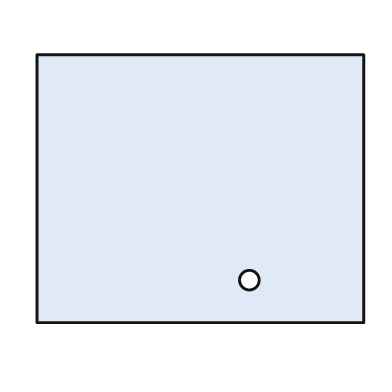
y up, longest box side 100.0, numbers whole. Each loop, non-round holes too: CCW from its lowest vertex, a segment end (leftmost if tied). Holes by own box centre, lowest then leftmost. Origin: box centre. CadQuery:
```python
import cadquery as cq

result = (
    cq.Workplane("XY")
    .moveTo(-50.0, -41.0)
    .lineTo(50.0, -41.0)
    .lineTo(50.0, 41.0)
    .lineTo(-50.0, 41.0)
    .close()
    .moveTo(15.0, -28.0)
    .circle(3.0)
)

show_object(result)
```